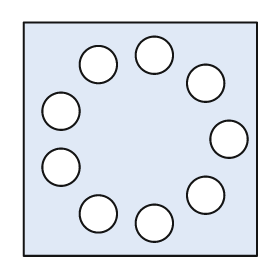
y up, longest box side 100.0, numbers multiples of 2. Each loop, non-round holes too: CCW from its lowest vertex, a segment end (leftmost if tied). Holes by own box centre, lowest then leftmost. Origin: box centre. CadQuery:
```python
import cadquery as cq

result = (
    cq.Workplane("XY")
    .moveTo(-50.0, -50.0)
    .lineTo(50.0, -50.0)
    .lineTo(50.0, 50.0)
    .lineTo(-50.0, 50.0)
    .close()
    .moveTo(6.0, -36.0)
    .circle(8.0)
    .moveTo(-18.0, -32.0)
    .circle(8.0)
    .moveTo(28.0, -24.0)
    .circle(8.0)
    .moveTo(-34.0, -12.0)
    .circle(8.0)
    .moveTo(38.0, 0.0)
    .circle(8.0)
    .moveTo(-34.0, 12.0)
    .circle(8.0)
    .moveTo(28.0, 24.0)
    .circle(8.0)
    .moveTo(-18.0, 32.0)
    .circle(8.0)
    .moveTo(6.0, 36.0)
    .circle(8.0)
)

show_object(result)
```